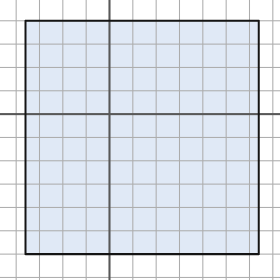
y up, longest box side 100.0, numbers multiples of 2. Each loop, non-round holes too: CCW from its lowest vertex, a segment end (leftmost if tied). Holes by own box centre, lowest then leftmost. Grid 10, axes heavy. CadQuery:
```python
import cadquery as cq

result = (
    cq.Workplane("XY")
    .moveTo(-36.0, -60.0)
    .lineTo(64.0, -60.0)
    .lineTo(64.0, 40.0)
    .lineTo(-36.0, 40.0)
    .close()
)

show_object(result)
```